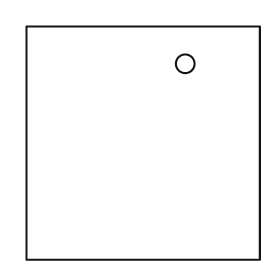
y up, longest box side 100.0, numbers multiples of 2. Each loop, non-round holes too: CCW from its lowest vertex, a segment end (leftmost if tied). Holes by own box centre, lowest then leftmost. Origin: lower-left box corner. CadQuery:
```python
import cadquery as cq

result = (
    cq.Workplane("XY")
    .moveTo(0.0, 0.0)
    .lineTo(100.0, 0.0)
    .lineTo(100.0, 100.0)
    .lineTo(0.0, 100.0)
    .close()
    .moveTo(68.0, 84.0)
    .circle(4.0)
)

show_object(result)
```